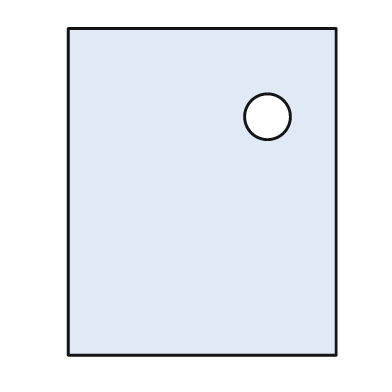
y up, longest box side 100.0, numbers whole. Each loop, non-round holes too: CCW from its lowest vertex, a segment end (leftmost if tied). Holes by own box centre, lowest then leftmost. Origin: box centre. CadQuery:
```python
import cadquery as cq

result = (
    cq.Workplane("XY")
    .moveTo(-41.0, -50.0)
    .lineTo(41.0, -50.0)
    .lineTo(41.0, 50.0)
    .lineTo(-41.0, 50.0)
    .close()
    .moveTo(20.0, 23.0)
    .circle(7.0)
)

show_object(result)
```